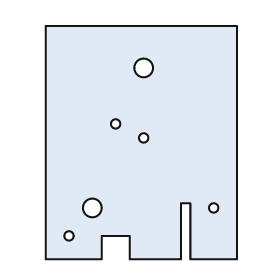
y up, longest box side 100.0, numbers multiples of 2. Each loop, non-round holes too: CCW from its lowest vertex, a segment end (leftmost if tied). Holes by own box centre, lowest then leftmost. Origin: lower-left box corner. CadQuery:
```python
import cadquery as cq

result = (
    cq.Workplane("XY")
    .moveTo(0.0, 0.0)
    .lineTo(24.0, 0.0)
    .lineTo(24.0, 10.0)
    .lineTo(36.0, 10.0)
    .lineTo(36.0, 0.0)
    .lineTo(58.0, 0.0)
    .lineTo(58.0, 24.0)
    .lineTo(62.0, 24.0)
    .lineTo(62.0, 0.0)
    .lineTo(82.0, 0.0)
    .lineTo(82.0, 100.0)
    .lineTo(0.0, 100.0)
    .close()
    .moveTo(10.0, 10.0)
    .circle(2.0)
    .moveTo(20.0, 22.0)
    .circle(4.0)
    .moveTo(72.0, 22.0)
    .circle(2.0)
    .moveTo(42.0, 52.0)
    .circle(2.0)
    .moveTo(30.0, 58.0)
    .circle(2.0)
    .moveTo(42.0, 82.0)
    .circle(4.0)
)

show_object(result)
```